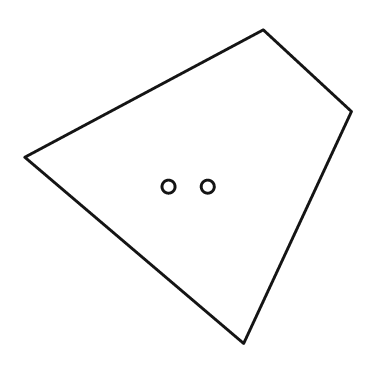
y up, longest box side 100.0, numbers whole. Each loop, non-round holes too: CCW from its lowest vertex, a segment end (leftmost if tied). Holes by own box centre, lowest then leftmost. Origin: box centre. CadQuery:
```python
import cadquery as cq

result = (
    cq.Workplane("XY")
    .moveTo(17.0, -48.0)
    .lineTo(50.0, 23.0)
    .lineTo(23.0, 48.0)
    .lineTo(-50.0, 9.0)
    .close()
    .moveTo(-6.0, 0.0)
    .circle(2.0)
    .moveTo(6.0, 0.0)
    .circle(2.0)
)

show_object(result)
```